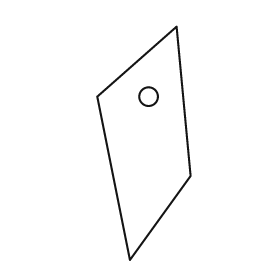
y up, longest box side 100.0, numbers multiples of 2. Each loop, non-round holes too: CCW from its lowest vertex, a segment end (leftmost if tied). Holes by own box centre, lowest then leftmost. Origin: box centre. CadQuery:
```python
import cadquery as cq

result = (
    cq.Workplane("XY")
    .moveTo(-6.0, -50.0)
    .lineTo(20.0, -14.0)
    .lineTo(14.0, 50.0)
    .lineTo(-20.0, 20.0)
    .close()
    .moveTo(2.0, 20.0)
    .circle(4.0)
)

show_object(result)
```